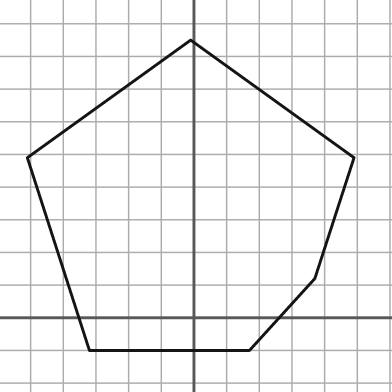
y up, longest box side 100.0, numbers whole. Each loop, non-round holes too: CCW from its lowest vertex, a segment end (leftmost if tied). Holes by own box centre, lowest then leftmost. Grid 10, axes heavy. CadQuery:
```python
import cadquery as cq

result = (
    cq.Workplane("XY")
    .moveTo(-32.0, -10.0)
    .lineTo(17.0, -10.0)
    .lineTo(37.0, 12.0)
    .lineTo(49.0, 49.0)
    .lineTo(-1.0, 85.0)
    .lineTo(-51.0, 49.0)
    .close()
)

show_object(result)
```